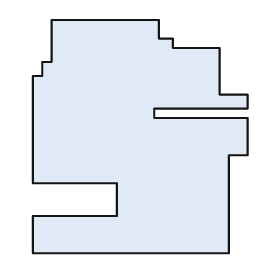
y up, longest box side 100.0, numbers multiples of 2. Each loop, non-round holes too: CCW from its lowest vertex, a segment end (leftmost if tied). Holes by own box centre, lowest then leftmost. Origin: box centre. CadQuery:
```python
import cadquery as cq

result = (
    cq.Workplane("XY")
    .moveTo(-46.0, -50.0)
    .lineTo(38.0, -50.0)
    .lineTo(38.0, -8.0)
    .lineTo(46.0, -8.0)
    .lineTo(46.0, 8.0)
    .lineTo(6.0, 8.0)
    .lineTo(6.0, 12.0)
    .lineTo(46.0, 12.0)
    .lineTo(46.0, 18.0)
    .lineTo(34.0, 18.0)
    .lineTo(34.0, 38.0)
    .lineTo(14.0, 38.0)
    .lineTo(14.0, 42.0)
    .lineTo(8.0, 42.0)
    .lineTo(8.0, 50.0)
    .lineTo(-38.0, 50.0)
    .lineTo(-38.0, 32.0)
    .lineTo(-42.0, 32.0)
    .lineTo(-42.0, 26.0)
    .lineTo(-46.0, 26.0)
    .lineTo(-46.0, -20.0)
    .lineTo(-10.0, -20.0)
    .lineTo(-10.0, -34.0)
    .lineTo(-46.0, -34.0)
    .close()
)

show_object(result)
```